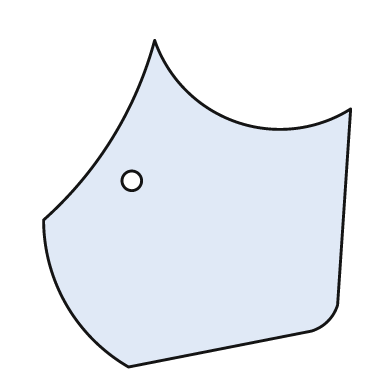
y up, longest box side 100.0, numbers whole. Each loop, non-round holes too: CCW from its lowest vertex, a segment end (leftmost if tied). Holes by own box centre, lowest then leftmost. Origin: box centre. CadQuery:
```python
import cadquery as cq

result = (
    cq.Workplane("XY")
    .moveTo(-21.0, -50.0)
    .lineTo(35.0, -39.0)
    .threePointArc((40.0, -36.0), (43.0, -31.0))
    .lineTo(47.0, 29.0)
    .threePointArc((12.0, 25.0), (-13.0, 50.0))
    .threePointArc((-26.0, 20.0), (-47.0, -5.0))
    .threePointArc((-40.0, -31.0), (-21.0, -50.0))
    .close()
    .moveTo(-20.0, 7.0)
    .circle(3.0)
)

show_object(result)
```